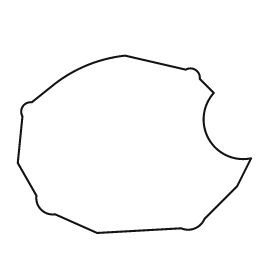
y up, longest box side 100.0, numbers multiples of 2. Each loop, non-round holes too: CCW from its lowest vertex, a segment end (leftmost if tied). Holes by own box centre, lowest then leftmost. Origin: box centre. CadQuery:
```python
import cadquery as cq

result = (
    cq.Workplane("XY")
    .moveTo(-16.0, -38.0)
    .lineTo(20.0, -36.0)
    .threePointArc((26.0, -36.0), (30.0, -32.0))
    .lineTo(44.0, -18.0)
    .lineTo(50.0, -6.0)
    .threePointArc((32.0, 2.0), (34.0, 22.0))
    .lineTo(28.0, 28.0)
    .threePointArc((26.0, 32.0), (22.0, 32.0))
    .lineTo(-4.0, 38.0)
    .threePointArc((-20.0, 34.0), (-34.0, 26.0))
    .lineTo(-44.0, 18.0)
    .threePointArc((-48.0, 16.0), (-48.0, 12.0))
    .lineTo(-50.0, -8.0)
    .lineTo(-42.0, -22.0)
    .threePointArc((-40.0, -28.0), (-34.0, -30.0))
    .close()
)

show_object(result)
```